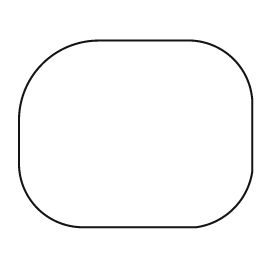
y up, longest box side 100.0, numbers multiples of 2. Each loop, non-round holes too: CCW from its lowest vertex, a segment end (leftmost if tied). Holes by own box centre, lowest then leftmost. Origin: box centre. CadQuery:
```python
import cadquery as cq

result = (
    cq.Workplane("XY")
    .moveTo(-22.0, -40.0)
    .lineTo(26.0, -40.0)
    .threePointArc((42.0, -32.0), (50.0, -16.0))
    .lineTo(50.0, 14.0)
    .threePointArc((42.0, 32.0), (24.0, 40.0))
    .lineTo(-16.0, 40.0)
    .threePointArc((-40.0, 30.0), (-50.0, 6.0))
    .lineTo(-50.0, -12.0)
    .threePointArc((-42.0, -32.0), (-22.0, -40.0))
    .close()
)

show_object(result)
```